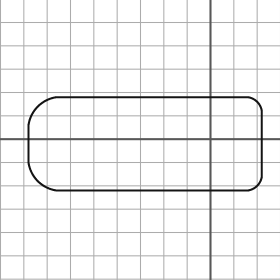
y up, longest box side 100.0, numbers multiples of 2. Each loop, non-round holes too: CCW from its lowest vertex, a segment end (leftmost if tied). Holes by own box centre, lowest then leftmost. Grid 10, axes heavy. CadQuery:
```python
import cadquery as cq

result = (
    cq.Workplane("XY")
    .moveTo(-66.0, -22.0)
    .lineTo(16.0, -22.0)
    .threePointArc((20.0, -20.0), (22.0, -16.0))
    .lineTo(22.0, 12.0)
    .threePointArc((20.0, 16.0), (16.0, 18.0))
    .lineTo(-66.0, 18.0)
    .threePointArc((-74.0, 14.0), (-78.0, 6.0))
    .lineTo(-78.0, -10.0)
    .threePointArc((-74.0, -18.0), (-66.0, -22.0))
    .close()
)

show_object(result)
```